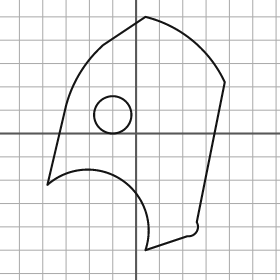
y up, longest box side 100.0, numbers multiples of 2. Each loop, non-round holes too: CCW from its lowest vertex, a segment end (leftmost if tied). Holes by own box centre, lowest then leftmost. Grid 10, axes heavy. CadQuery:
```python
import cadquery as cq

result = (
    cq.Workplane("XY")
    .moveTo(4.0, -50.0)
    .lineTo(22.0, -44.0)
    .threePointArc((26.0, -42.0), (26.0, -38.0))
    .lineTo(38.0, 22.0)
    .threePointArc((24.0, 40.0), (4.0, 50.0))
    .lineTo(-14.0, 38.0)
    .threePointArc((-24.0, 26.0), (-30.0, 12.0))
    .lineTo(-38.0, -22.0)
    .threePointArc((-6.0, -20.0), (4.0, -50.0))
    .close()
    .moveTo(-10.0, 8.0)
    .circle(8.0)
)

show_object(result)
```